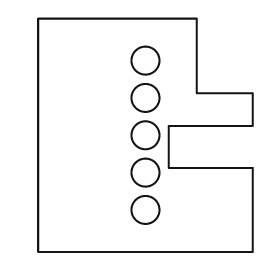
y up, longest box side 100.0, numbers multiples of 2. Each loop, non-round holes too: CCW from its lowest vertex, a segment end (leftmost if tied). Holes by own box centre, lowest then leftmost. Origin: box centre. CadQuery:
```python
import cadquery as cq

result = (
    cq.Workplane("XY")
    .moveTo(-46.0, -50.0)
    .lineTo(46.0, -50.0)
    .lineTo(46.0, -14.0)
    .lineTo(10.0, -14.0)
    .lineTo(10.0, 4.0)
    .lineTo(46.0, 4.0)
    .lineTo(46.0, 18.0)
    .lineTo(22.0, 18.0)
    .lineTo(22.0, 50.0)
    .lineTo(-46.0, 50.0)
    .close()
    .moveTo(0.0, -32.0)
    .circle(6.0)
    .moveTo(0.0, -16.0)
    .circle(6.0)
    .moveTo(0.0, 0.0)
    .circle(6.0)
    .moveTo(0.0, 16.0)
    .circle(6.0)
    .moveTo(0.0, 32.0)
    .circle(6.0)
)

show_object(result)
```